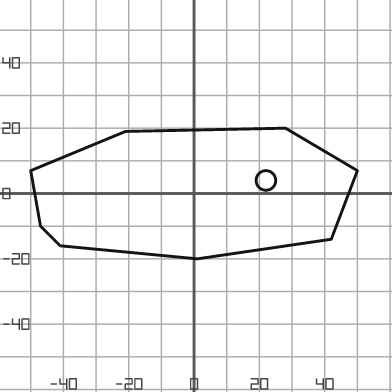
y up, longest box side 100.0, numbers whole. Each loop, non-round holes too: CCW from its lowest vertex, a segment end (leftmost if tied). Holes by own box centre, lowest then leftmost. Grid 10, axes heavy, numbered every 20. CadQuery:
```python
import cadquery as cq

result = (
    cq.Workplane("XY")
    .moveTo(1.0, -20.0)
    .lineTo(42.0, -14.0)
    .lineTo(50.0, 7.0)
    .lineTo(28.0, 20.0)
    .lineTo(-21.0, 19.0)
    .lineTo(-50.0, 7.0)
    .lineTo(-47.0, -10.0)
    .lineTo(-41.0, -16.0)
    .close()
    .moveTo(22.0, 4.0)
    .circle(3.0)
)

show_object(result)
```